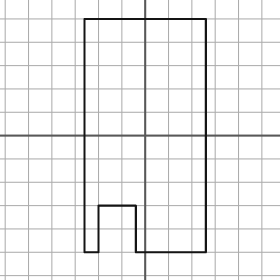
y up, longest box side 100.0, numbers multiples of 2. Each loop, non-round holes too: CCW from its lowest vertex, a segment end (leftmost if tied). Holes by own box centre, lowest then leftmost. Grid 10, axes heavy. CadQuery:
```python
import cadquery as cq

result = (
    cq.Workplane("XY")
    .moveTo(-26.0, -50.0)
    .lineTo(-20.0, -50.0)
    .lineTo(-20.0, -30.0)
    .lineTo(-4.0, -30.0)
    .lineTo(-4.0, -50.0)
    .lineTo(26.0, -50.0)
    .lineTo(26.0, 50.0)
    .lineTo(-26.0, 50.0)
    .close()
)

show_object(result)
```